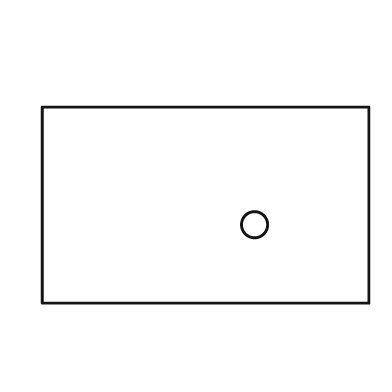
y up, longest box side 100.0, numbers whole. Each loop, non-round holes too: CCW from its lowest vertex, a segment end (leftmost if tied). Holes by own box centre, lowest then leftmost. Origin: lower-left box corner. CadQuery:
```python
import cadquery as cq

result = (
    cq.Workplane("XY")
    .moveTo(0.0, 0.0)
    .lineTo(100.0, 0.0)
    .lineTo(100.0, 60.0)
    .lineTo(0.0, 60.0)
    .close()
    .moveTo(65.0, 24.0)
    .circle(4.0)
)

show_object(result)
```